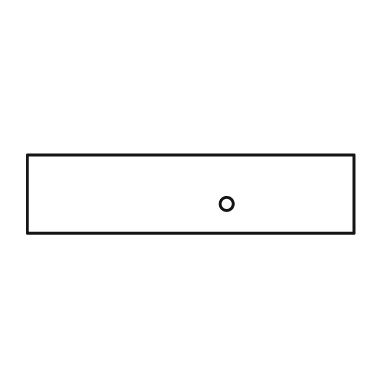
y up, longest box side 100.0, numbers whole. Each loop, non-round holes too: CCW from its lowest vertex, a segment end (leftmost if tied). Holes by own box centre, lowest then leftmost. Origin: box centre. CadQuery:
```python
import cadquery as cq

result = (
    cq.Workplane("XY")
    .moveTo(-50.0, -12.0)
    .lineTo(50.0, -12.0)
    .lineTo(50.0, 12.0)
    .lineTo(-50.0, 12.0)
    .close()
    .moveTo(11.0, -3.0)
    .circle(2.0)
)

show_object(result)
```